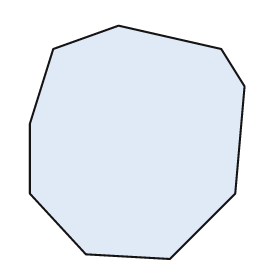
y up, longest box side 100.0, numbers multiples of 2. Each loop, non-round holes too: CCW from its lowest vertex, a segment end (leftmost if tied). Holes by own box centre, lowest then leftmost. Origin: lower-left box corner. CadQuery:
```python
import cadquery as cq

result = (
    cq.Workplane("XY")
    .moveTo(60.0, 0.0)
    .lineTo(88.0, 28.0)
    .lineTo(92.0, 74.0)
    .lineTo(82.0, 90.0)
    .lineTo(38.0, 100.0)
    .lineTo(10.0, 90.0)
    .lineTo(0.0, 58.0)
    .lineTo(0.0, 28.0)
    .lineTo(24.0, 2.0)
    .close()
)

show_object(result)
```